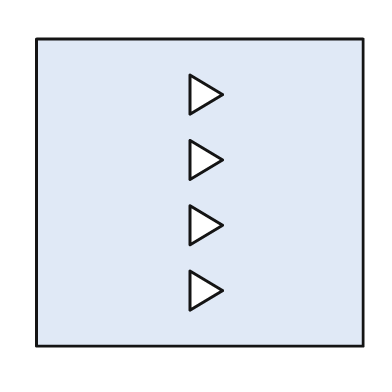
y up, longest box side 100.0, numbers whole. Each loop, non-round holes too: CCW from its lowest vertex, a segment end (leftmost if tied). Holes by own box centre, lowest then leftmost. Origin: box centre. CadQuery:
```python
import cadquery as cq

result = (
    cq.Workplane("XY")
    .moveTo(-50.0, -47.0)
    .lineTo(50.0, -47.0)
    .lineTo(50.0, 47.0)
    .lineTo(-50.0, 47.0)
    .close()
    .moveTo(-3.0, -36.0)
    .lineTo(7.0, -30.0)
    .lineTo(-3.0, -24.0)
    .close()
    .moveTo(-3.0, -16.0)
    .lineTo(7.0, -10.0)
    .lineTo(-3.0, -4.0)
    .close()
    .moveTo(-3.0, 4.0)
    .lineTo(7.0, 10.0)
    .lineTo(-3.0, 16.0)
    .close()
    .moveTo(-3.0, 24.0)
    .lineTo(7.0, 30.0)
    .lineTo(-3.0, 36.0)
    .close()
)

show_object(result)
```